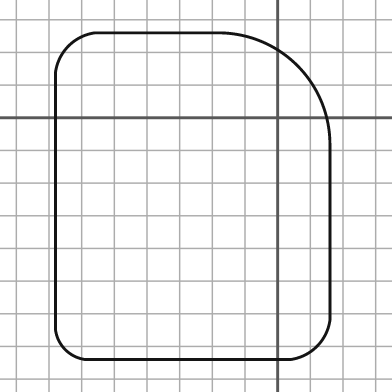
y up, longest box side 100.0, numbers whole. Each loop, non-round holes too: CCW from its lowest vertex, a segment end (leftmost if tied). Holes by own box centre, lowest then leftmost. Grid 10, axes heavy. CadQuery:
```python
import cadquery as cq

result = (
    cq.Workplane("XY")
    .moveTo(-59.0, -74.0)
    .lineTo(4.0, -74.0)
    .threePointArc((12.0, -70.0), (16.0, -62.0))
    .lineTo(16.0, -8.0)
    .threePointArc((6.0, 16.0), (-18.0, 26.0))
    .lineTo(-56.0, 26.0)
    .threePointArc((-64.0, 22.0), (-68.0, 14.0))
    .lineTo(-68.0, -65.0)
    .threePointArc((-65.0, -71.0), (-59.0, -74.0))
    .close()
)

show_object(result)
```